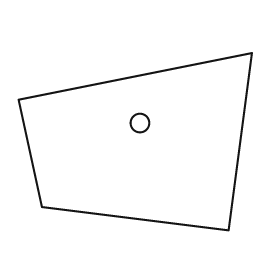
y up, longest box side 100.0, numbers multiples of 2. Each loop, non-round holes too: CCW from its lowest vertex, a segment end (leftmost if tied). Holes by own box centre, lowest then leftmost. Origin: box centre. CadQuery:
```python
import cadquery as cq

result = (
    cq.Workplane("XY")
    .moveTo(40.0, -38.0)
    .lineTo(50.0, 38.0)
    .lineTo(-50.0, 18.0)
    .lineTo(-40.0, -28.0)
    .close()
    .moveTo(2.0, 8.0)
    .circle(4.0)
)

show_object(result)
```